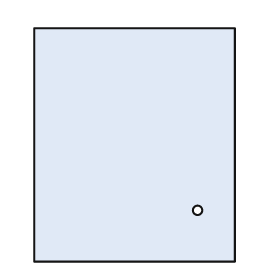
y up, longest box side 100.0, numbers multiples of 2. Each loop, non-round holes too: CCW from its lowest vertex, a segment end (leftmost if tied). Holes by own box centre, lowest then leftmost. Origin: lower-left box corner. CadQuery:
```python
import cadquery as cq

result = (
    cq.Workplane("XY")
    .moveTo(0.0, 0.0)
    .lineTo(86.0, 0.0)
    .lineTo(86.0, 100.0)
    .lineTo(0.0, 100.0)
    .close()
    .moveTo(70.0, 22.0)
    .circle(2.0)
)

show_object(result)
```